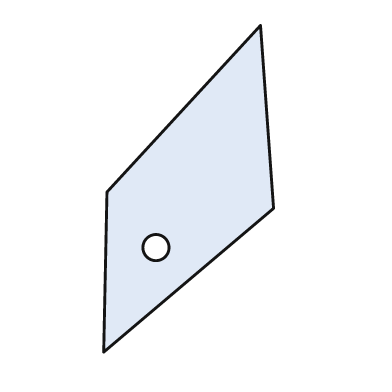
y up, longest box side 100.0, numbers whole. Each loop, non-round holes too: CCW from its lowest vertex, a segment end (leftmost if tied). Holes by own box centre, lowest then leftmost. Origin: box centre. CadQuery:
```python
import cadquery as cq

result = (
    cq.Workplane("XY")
    .moveTo(-26.0, -50.0)
    .lineTo(26.0, -6.0)
    .lineTo(22.0, 50.0)
    .lineTo(-25.0, -1.0)
    .close()
    .moveTo(-10.0, -18.0)
    .circle(4.0)
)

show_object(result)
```